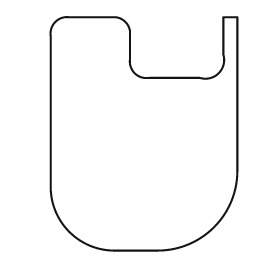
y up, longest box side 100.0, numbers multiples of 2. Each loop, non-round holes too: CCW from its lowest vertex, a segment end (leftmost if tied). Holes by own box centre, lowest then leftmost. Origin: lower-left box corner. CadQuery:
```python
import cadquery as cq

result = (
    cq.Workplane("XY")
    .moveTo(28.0, 0.0)
    .lineTo(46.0, 0.0)
    .threePointArc((70.0, 10.0), (80.0, 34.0))
    .lineTo(80.0, 100.0)
    .lineTo(74.0, 100.0)
    .lineTo(74.0, 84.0)
    .threePointArc((72.0, 76.0), (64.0, 74.0))
    .lineTo(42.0, 74.0)
    .threePointArc((36.0, 76.0), (34.0, 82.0))
    .lineTo(34.0, 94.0)
    .threePointArc((32.0, 98.0), (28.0, 100.0))
    .lineTo(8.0, 100.0)
    .threePointArc((2.0, 98.0), (0.0, 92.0))
    .lineTo(0.0, 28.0)
    .threePointArc((8.0, 8.0), (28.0, 0.0))
    .close()
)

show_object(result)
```